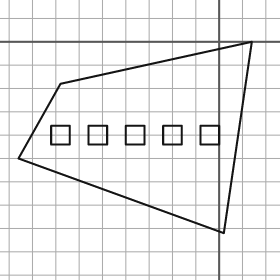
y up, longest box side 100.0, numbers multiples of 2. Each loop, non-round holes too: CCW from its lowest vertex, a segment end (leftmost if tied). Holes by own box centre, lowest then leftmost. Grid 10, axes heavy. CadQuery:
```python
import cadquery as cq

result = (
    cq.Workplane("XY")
    .moveTo(2.0, -82.0)
    .lineTo(14.0, 0.0)
    .lineTo(-68.0, -18.0)
    .lineTo(-86.0, -50.0)
    .close()
    .moveTo(-72.0, -44.0)
    .lineTo(-64.0, -44.0)
    .lineTo(-64.0, -36.0)
    .lineTo(-72.0, -36.0)
    .close()
    .moveTo(-56.0, -44.0)
    .lineTo(-48.0, -44.0)
    .lineTo(-48.0, -36.0)
    .lineTo(-56.0, -36.0)
    .close()
    .moveTo(-40.0, -44.0)
    .lineTo(-32.0, -44.0)
    .lineTo(-32.0, -36.0)
    .lineTo(-40.0, -36.0)
    .close()
    .moveTo(-24.0, -44.0)
    .lineTo(-16.0, -44.0)
    .lineTo(-16.0, -36.0)
    .lineTo(-24.0, -36.0)
    .close()
    .moveTo(-8.0, -44.0)
    .lineTo(0.0, -44.0)
    .lineTo(0.0, -36.0)
    .lineTo(-8.0, -36.0)
    .close()
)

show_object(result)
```